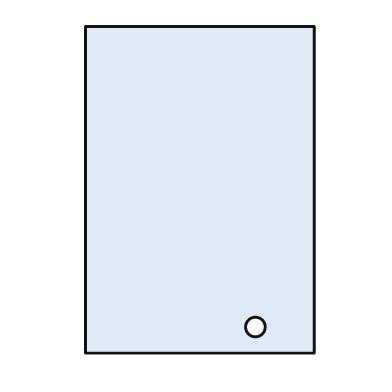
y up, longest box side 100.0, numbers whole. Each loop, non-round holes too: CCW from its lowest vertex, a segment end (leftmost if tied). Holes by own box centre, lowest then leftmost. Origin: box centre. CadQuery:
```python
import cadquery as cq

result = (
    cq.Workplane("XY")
    .moveTo(-35.0, -50.0)
    .lineTo(35.0, -50.0)
    .lineTo(35.0, 50.0)
    .lineTo(-35.0, 50.0)
    .close()
    .moveTo(17.0, -42.0)
    .circle(3.0)
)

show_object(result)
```